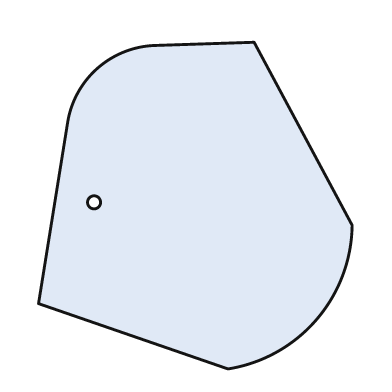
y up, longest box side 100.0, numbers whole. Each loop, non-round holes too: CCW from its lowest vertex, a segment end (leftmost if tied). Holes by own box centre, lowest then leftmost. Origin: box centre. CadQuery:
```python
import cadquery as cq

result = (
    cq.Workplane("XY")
    .moveTo(10.0, -50.0)
    .threePointArc((37.0, -35.0), (48.0, -6.0))
    .lineTo(18.0, 50.0)
    .lineTo(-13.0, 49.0)
    .threePointArc((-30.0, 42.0), (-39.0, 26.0))
    .lineTo(-48.0, -30.0)
    .close()
    .moveTo(-31.0, 1.0)
    .circle(2.0)
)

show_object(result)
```